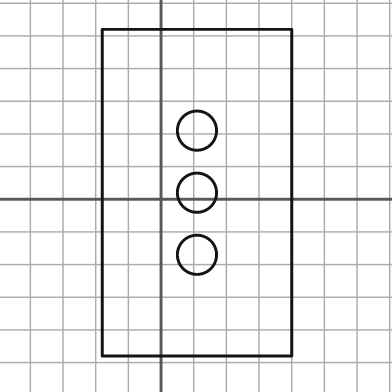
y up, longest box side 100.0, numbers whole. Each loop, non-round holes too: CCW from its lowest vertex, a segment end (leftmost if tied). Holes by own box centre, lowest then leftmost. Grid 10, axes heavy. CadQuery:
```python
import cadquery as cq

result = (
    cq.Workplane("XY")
    .moveTo(-18.0, -48.0)
    .lineTo(40.0, -48.0)
    .lineTo(40.0, 52.0)
    .lineTo(-18.0, 52.0)
    .close()
    .moveTo(11.0, -17.0)
    .circle(6.0)
    .moveTo(11.0, 2.0)
    .circle(6.0)
    .moveTo(11.0, 21.0)
    .circle(6.0)
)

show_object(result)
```